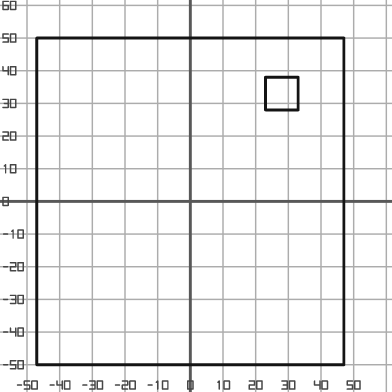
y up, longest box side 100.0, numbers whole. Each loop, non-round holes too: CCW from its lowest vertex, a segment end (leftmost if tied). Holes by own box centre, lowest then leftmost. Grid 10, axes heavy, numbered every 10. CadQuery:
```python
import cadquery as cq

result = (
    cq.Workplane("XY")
    .moveTo(-47.0, -50.0)
    .lineTo(47.0, -50.0)
    .lineTo(47.0, 50.0)
    .lineTo(-47.0, 50.0)
    .close()
    .moveTo(23.0, 28.0)
    .lineTo(33.0, 28.0)
    .lineTo(33.0, 38.0)
    .lineTo(23.0, 38.0)
    .close()
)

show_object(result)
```